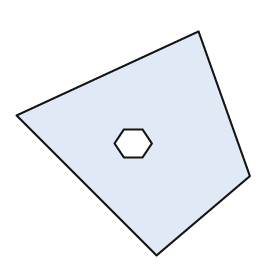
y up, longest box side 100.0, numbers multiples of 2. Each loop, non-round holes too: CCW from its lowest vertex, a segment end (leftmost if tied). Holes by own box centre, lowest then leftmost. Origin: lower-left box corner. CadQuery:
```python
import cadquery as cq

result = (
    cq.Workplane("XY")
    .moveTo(60.0, 0.0)
    .lineTo(100.0, 34.0)
    .lineTo(78.0, 96.0)
    .lineTo(0.0, 60.0)
    .close()
    .moveTo(46.0, 42.0)
    .lineTo(54.0, 42.0)
    .lineTo(58.0, 48.0)
    .lineTo(54.0, 54.0)
    .lineTo(46.0, 54.0)
    .lineTo(42.0, 48.0)
    .close()
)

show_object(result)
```